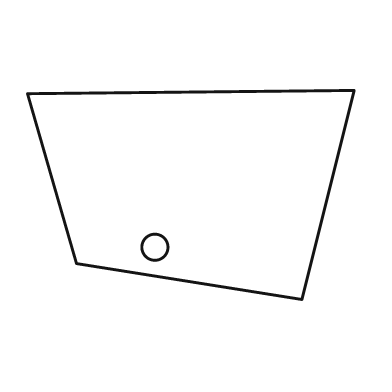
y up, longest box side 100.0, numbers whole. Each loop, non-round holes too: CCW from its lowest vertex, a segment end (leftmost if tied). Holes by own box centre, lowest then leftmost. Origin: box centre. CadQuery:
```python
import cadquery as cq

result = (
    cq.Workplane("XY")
    .moveTo(34.0, -32.0)
    .lineTo(50.0, 32.0)
    .lineTo(-50.0, 31.0)
    .lineTo(-35.0, -21.0)
    .close()
    .moveTo(-11.0, -16.0)
    .circle(4.0)
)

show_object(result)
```